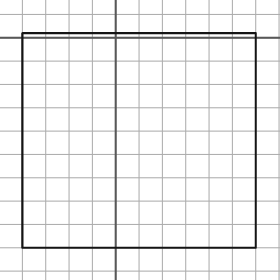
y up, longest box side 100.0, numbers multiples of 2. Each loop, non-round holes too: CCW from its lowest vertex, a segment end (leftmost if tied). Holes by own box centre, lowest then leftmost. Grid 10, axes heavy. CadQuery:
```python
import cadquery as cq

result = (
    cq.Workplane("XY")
    .moveTo(-40.0, -90.0)
    .lineTo(60.0, -90.0)
    .lineTo(60.0, 2.0)
    .lineTo(-40.0, 2.0)
    .close()
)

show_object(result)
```